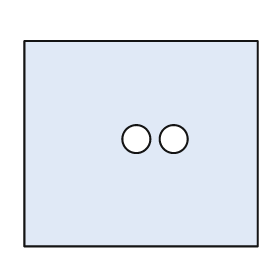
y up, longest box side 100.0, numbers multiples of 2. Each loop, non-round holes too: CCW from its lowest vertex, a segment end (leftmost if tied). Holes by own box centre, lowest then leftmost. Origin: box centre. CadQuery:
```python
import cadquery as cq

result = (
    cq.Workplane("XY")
    .moveTo(-50.0, -44.0)
    .lineTo(50.0, -44.0)
    .lineTo(50.0, 44.0)
    .lineTo(-50.0, 44.0)
    .close()
    .moveTo(-2.0, 2.0)
    .circle(6.0)
    .moveTo(14.0, 2.0)
    .circle(6.0)
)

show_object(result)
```